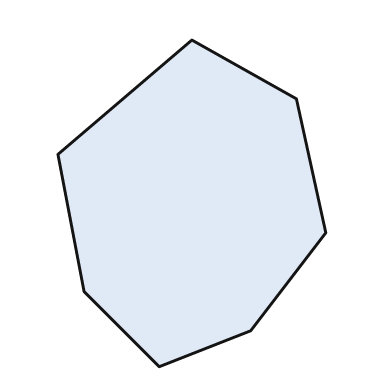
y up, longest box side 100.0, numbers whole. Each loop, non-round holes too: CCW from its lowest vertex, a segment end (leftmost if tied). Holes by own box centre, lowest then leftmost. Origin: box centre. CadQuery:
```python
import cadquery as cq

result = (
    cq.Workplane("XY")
    .moveTo(-10.0, -50.0)
    .lineTo(18.0, -39.0)
    .lineTo(41.0, -9.0)
    .lineTo(32.0, 32.0)
    .lineTo(0.0, 50.0)
    .lineTo(-41.0, 15.0)
    .lineTo(-33.0, -27.0)
    .close()
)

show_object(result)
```